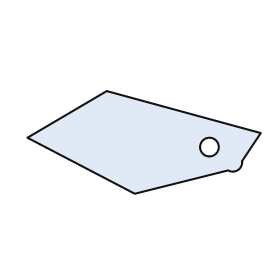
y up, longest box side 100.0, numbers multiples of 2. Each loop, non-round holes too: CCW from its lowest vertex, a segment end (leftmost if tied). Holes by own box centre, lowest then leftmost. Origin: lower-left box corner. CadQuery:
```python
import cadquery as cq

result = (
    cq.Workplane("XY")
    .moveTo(46.0, 0.0)
    .lineTo(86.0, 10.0)
    .threePointArc((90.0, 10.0), (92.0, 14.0))
    .lineTo(100.0, 26.0)
    .lineTo(34.0, 44.0)
    .lineTo(0.0, 24.0)
    .close()
    .moveTo(78.0, 20.0)
    .circle(4.0)
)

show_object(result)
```